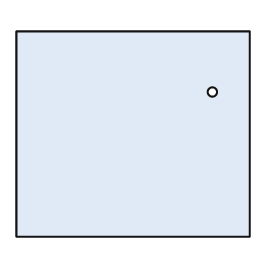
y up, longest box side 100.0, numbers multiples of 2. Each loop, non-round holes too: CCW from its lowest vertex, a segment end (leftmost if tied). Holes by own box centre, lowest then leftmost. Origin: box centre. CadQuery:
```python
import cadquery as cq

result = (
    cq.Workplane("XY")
    .moveTo(-50.0, -44.0)
    .lineTo(50.0, -44.0)
    .lineTo(50.0, 44.0)
    .lineTo(-50.0, 44.0)
    .close()
    .moveTo(34.0, 18.0)
    .circle(2.0)
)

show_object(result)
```